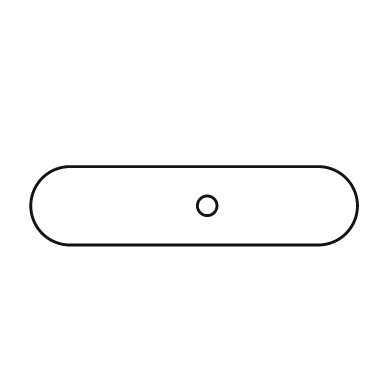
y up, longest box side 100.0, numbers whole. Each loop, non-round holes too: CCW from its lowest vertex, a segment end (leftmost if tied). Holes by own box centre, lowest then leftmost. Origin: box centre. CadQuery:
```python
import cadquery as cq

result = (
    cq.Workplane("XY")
    .moveTo(-38.0, -12.0)
    .lineTo(38.0, -12.0)
    .threePointArc((50.0, 0.0), (38.0, 12.0))
    .lineTo(-38.0, 12.0)
    .threePointArc((-50.0, 0.0), (-38.0, -12.0))
    .close()
    .moveTo(4.0, 0.0)
    .circle(3.0)
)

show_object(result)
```